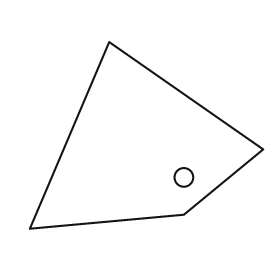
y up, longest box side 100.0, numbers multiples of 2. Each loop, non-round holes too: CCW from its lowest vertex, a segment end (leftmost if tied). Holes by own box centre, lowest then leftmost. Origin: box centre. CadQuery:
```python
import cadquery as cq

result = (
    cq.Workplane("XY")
    .moveTo(-50.0, -40.0)
    .lineTo(16.0, -34.0)
    .lineTo(50.0, -6.0)
    .lineTo(-16.0, 40.0)
    .close()
    .moveTo(16.0, -18.0)
    .circle(4.0)
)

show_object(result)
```